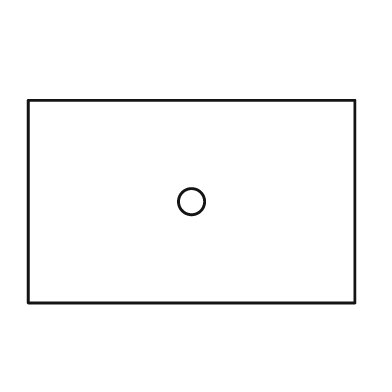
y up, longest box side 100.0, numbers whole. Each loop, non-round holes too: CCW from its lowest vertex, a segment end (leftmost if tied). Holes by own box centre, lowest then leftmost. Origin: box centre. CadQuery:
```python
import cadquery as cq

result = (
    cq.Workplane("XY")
    .moveTo(-50.0, -31.0)
    .lineTo(50.0, -31.0)
    .lineTo(50.0, 31.0)
    .lineTo(-50.0, 31.0)
    .close()
    .moveTo(0.0, 0.0)
    .circle(4.0)
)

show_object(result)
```